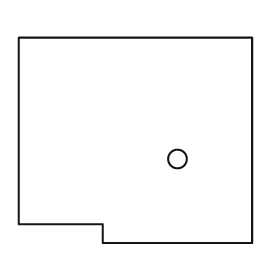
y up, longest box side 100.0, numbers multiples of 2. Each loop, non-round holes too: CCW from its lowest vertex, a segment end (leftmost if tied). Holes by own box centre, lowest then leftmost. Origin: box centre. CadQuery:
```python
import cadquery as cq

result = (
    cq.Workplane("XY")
    .moveTo(-14.0, -44.0)
    .lineTo(50.0, -44.0)
    .lineTo(50.0, 44.0)
    .lineTo(-50.0, 44.0)
    .lineTo(-50.0, -36.0)
    .lineTo(-14.0, -36.0)
    .close()
    .moveTo(18.0, -8.0)
    .circle(4.0)
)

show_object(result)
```